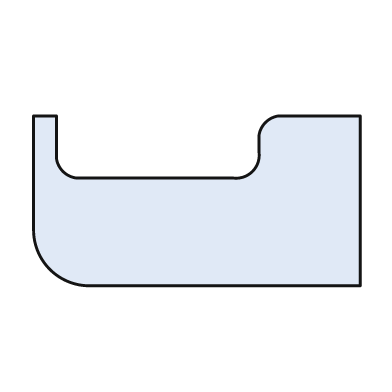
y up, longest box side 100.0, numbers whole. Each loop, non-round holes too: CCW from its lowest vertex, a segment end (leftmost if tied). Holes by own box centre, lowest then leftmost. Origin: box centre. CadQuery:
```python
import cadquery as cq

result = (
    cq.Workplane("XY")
    .moveTo(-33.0, -26.0)
    .lineTo(50.0, -26.0)
    .lineTo(50.0, 26.0)
    .lineTo(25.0, 26.0)
    .threePointArc((21.0, 24.0), (19.0, 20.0))
    .lineTo(19.0, 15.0)
    .threePointArc((17.0, 9.0), (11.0, 7.0))
    .lineTo(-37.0, 7.0)
    .threePointArc((-41.0, 9.0), (-43.0, 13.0))
    .lineTo(-43.0, 26.0)
    .lineTo(-50.0, 26.0)
    .lineTo(-50.0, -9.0)
    .threePointArc((-45.0, -21.0), (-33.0, -26.0))
    .close()
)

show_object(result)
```